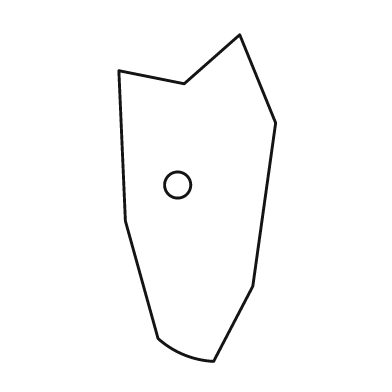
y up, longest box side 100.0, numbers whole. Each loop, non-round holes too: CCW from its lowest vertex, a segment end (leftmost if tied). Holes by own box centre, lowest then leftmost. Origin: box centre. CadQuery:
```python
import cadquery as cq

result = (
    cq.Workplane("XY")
    .moveTo(5.0, -50.0)
    .lineTo(17.0, -27.0)
    .lineTo(24.0, 23.0)
    .lineTo(13.0, 50.0)
    .lineTo(-4.0, 35.0)
    .lineTo(-24.0, 39.0)
    .lineTo(-22.0, -7.0)
    .lineTo(-12.0, -43.0)
    .threePointArc((-4.0, -48.0), (5.0, -50.0))
    .close()
    .moveTo(-6.0, 4.0)
    .circle(4.0)
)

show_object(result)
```